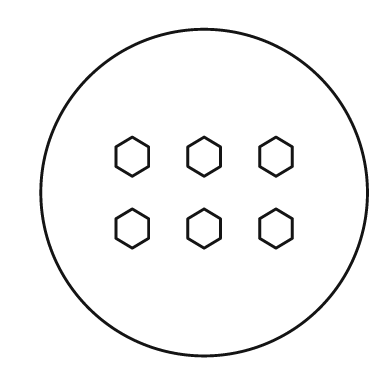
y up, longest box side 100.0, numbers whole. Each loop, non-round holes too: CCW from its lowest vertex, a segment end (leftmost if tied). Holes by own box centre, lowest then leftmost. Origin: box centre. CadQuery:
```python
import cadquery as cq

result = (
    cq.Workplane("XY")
    .moveTo(0.0, 0.0)
    .circle(50.0)
    .moveTo(-22.0, -17.0)
    .lineTo(-17.0, -14.0)
    .lineTo(-17.0, -8.0)
    .lineTo(-22.0, -5.0)
    .lineTo(-27.0, -8.0)
    .lineTo(-27.0, -14.0)
    .close()
    .moveTo(0.0, -17.0)
    .lineTo(5.0, -14.0)
    .lineTo(5.0, -8.0)
    .lineTo(0.0, -5.0)
    .lineTo(-5.0, -8.0)
    .lineTo(-5.0, -14.0)
    .close()
    .moveTo(22.0, -17.0)
    .lineTo(27.0, -14.0)
    .lineTo(27.0, -8.0)
    .lineTo(22.0, -5.0)
    .lineTo(17.0, -8.0)
    .lineTo(17.0, -14.0)
    .close()
    .moveTo(-22.0, 5.0)
    .lineTo(-17.0, 8.0)
    .lineTo(-17.0, 14.0)
    .lineTo(-22.0, 17.0)
    .lineTo(-27.0, 14.0)
    .lineTo(-27.0, 8.0)
    .close()
    .moveTo(0.0, 5.0)
    .lineTo(5.0, 8.0)
    .lineTo(5.0, 14.0)
    .lineTo(0.0, 17.0)
    .lineTo(-5.0, 14.0)
    .lineTo(-5.0, 8.0)
    .close()
    .moveTo(22.0, 5.0)
    .lineTo(27.0, 8.0)
    .lineTo(27.0, 14.0)
    .lineTo(22.0, 17.0)
    .lineTo(17.0, 14.0)
    .lineTo(17.0, 8.0)
    .close()
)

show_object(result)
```